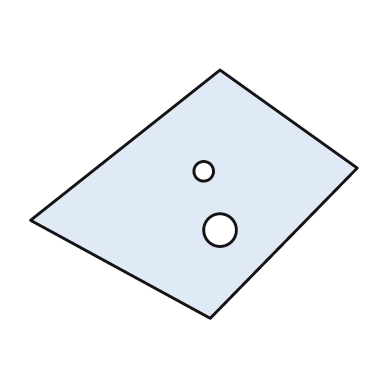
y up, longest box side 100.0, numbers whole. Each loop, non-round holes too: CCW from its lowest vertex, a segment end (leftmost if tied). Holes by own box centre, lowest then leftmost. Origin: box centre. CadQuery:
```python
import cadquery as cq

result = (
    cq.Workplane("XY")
    .moveTo(5.0, -38.0)
    .lineTo(50.0, 8.0)
    .lineTo(8.0, 38.0)
    .lineTo(-50.0, -8.0)
    .close()
    .moveTo(8.0, -11.0)
    .circle(5.0)
    .moveTo(3.0, 7.0)
    .circle(3.0)
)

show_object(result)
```